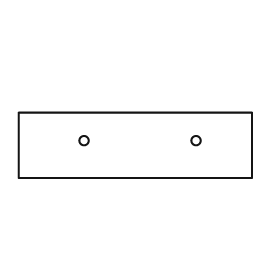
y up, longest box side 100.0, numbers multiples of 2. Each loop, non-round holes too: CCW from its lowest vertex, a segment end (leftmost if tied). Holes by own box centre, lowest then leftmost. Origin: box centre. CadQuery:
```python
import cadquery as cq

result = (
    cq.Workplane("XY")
    .moveTo(-50.0, -14.0)
    .lineTo(50.0, -14.0)
    .lineTo(50.0, 14.0)
    .lineTo(-50.0, 14.0)
    .close()
    .moveTo(-22.0, 2.0)
    .circle(2.0)
    .moveTo(26.0, 2.0)
    .circle(2.0)
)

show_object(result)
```